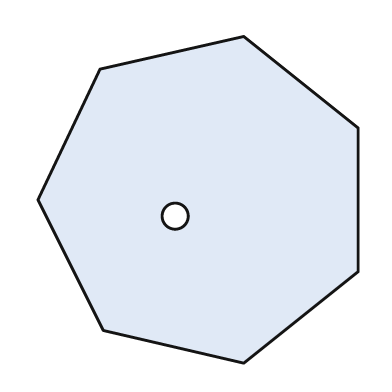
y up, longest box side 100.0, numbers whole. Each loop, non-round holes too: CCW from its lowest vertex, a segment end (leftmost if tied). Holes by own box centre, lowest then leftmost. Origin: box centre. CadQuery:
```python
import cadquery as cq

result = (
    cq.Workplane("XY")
    .moveTo(14.0, -50.0)
    .lineTo(49.0, -22.0)
    .lineTo(49.0, 22.0)
    .lineTo(14.0, 50.0)
    .lineTo(-30.0, 40.0)
    .lineTo(-49.0, 0.0)
    .lineTo(-29.0, -40.0)
    .close()
    .moveTo(-7.0, -5.0)
    .circle(4.0)
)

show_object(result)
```